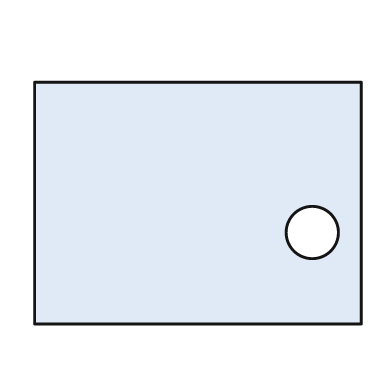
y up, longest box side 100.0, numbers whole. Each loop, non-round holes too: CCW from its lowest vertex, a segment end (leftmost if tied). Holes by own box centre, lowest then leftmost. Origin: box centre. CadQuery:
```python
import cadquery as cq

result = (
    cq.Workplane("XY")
    .moveTo(-50.0, -37.0)
    .lineTo(50.0, -37.0)
    .lineTo(50.0, 37.0)
    .lineTo(-50.0, 37.0)
    .close()
    .moveTo(35.0, -9.0)
    .circle(8.0)
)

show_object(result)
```